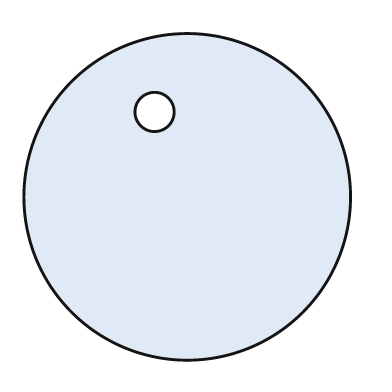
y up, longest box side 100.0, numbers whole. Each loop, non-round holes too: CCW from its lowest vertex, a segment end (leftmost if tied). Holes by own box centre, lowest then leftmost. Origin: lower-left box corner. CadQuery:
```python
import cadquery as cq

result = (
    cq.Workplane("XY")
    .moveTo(50.0, 50.0)
    .circle(50.0)
    .moveTo(40.0, 76.0)
    .circle(6.0)
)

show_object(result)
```